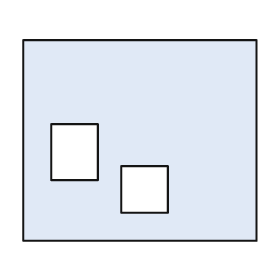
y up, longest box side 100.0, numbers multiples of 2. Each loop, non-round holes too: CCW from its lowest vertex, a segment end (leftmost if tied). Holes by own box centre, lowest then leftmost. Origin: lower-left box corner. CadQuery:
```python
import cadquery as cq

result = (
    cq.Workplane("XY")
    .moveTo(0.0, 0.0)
    .lineTo(100.0, 0.0)
    .lineTo(100.0, 86.0)
    .lineTo(0.0, 86.0)
    .close()
    .moveTo(42.0, 12.0)
    .lineTo(62.0, 12.0)
    .lineTo(62.0, 32.0)
    .lineTo(42.0, 32.0)
    .close()
    .moveTo(12.0, 26.0)
    .lineTo(32.0, 26.0)
    .lineTo(32.0, 50.0)
    .lineTo(12.0, 50.0)
    .close()
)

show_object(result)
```